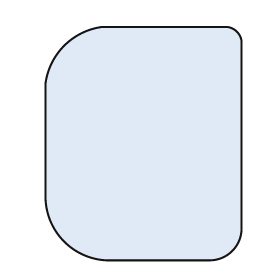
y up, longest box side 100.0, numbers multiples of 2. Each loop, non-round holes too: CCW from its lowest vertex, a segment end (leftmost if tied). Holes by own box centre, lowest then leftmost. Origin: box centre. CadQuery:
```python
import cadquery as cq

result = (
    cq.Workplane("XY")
    .moveTo(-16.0, -50.0)
    .lineTo(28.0, -50.0)
    .threePointArc((38.0, -46.0), (42.0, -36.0))
    .lineTo(42.0, 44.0)
    .threePointArc((40.0, 48.0), (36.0, 50.0))
    .lineTo(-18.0, 50.0)
    .threePointArc((-34.0, 42.0), (-42.0, 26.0))
    .lineTo(-42.0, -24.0)
    .threePointArc((-34.0, -42.0), (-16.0, -50.0))
    .close()
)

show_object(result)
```